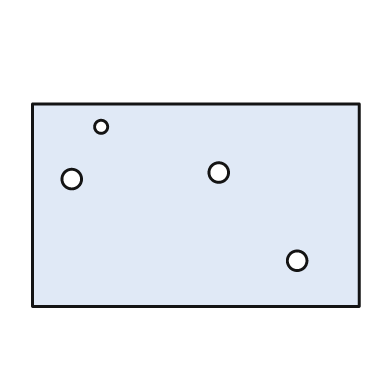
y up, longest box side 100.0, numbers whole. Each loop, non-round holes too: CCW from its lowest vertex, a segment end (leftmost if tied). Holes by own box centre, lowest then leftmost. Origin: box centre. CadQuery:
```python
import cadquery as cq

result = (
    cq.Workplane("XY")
    .moveTo(-50.0, -31.0)
    .lineTo(50.0, -31.0)
    .lineTo(50.0, 31.0)
    .lineTo(-50.0, 31.0)
    .close()
    .moveTo(31.0, -17.0)
    .circle(3.0)
    .moveTo(-38.0, 8.0)
    .circle(3.0)
    .moveTo(7.0, 10.0)
    .circle(3.0)
    .moveTo(-29.0, 24.0)
    .circle(2.0)
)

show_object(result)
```